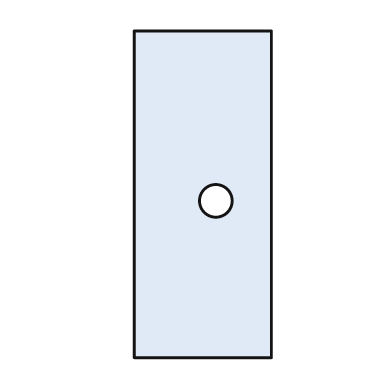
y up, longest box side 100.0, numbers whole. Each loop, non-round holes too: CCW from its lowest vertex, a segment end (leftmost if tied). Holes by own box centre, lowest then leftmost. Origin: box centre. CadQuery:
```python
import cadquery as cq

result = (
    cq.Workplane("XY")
    .moveTo(-21.0, -50.0)
    .lineTo(21.0, -50.0)
    .lineTo(21.0, 50.0)
    .lineTo(-21.0, 50.0)
    .close()
    .moveTo(4.0, -2.0)
    .circle(5.0)
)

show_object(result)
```